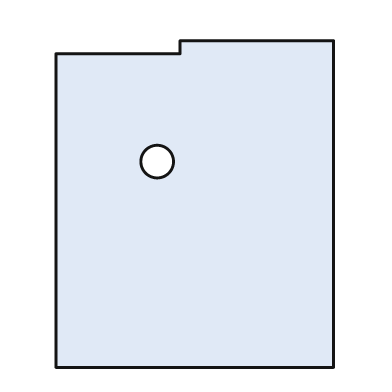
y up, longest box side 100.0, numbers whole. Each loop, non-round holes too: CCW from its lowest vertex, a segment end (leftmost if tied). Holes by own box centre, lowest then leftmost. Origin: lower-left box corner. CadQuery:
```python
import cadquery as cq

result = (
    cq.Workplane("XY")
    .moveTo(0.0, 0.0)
    .lineTo(85.0, 0.0)
    .lineTo(85.0, 100.0)
    .lineTo(38.0, 100.0)
    .lineTo(38.0, 96.0)
    .lineTo(0.0, 96.0)
    .close()
    .moveTo(31.0, 63.0)
    .circle(5.0)
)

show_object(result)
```